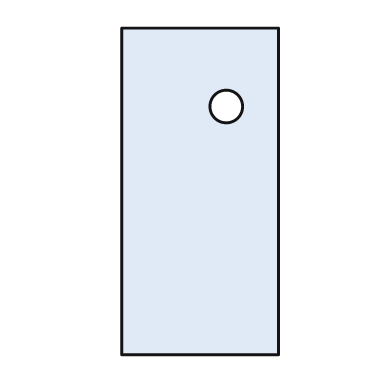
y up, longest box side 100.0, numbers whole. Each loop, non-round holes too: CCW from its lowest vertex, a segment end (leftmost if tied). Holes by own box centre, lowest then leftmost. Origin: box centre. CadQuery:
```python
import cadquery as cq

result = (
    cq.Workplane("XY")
    .moveTo(-24.0, -50.0)
    .lineTo(24.0, -50.0)
    .lineTo(24.0, 50.0)
    .lineTo(-24.0, 50.0)
    .close()
    .moveTo(8.0, 26.0)
    .circle(5.0)
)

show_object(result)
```